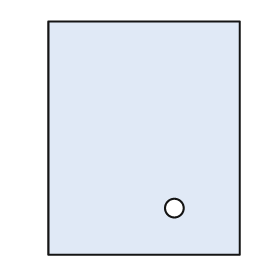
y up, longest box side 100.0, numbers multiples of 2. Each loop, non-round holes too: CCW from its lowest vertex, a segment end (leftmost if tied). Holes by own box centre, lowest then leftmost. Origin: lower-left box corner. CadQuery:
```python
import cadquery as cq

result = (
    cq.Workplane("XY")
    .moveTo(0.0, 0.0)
    .lineTo(82.0, 0.0)
    .lineTo(82.0, 100.0)
    .lineTo(0.0, 100.0)
    .close()
    .moveTo(54.0, 20.0)
    .circle(4.0)
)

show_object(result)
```